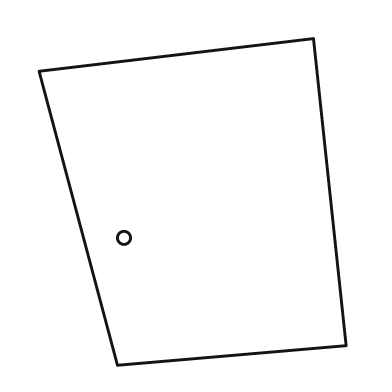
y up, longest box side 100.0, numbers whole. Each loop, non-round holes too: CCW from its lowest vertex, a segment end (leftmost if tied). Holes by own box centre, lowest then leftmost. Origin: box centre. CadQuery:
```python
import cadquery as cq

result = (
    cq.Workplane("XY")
    .moveTo(-23.0, -50.0)
    .lineTo(47.0, -44.0)
    .lineTo(37.0, 50.0)
    .lineTo(-47.0, 40.0)
    .close()
    .moveTo(-21.0, -11.0)
    .circle(2.0)
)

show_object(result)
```